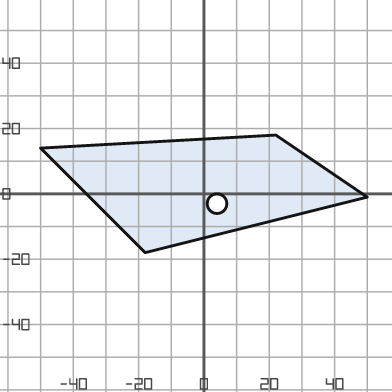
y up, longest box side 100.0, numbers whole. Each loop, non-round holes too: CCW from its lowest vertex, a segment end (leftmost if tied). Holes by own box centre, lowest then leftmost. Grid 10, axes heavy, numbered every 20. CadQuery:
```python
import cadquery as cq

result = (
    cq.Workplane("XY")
    .moveTo(-18.0, -18.0)
    .lineTo(50.0, -1.0)
    .lineTo(22.0, 18.0)
    .lineTo(-50.0, 14.0)
    .close()
    .moveTo(4.0, -3.0)
    .circle(3.0)
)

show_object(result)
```